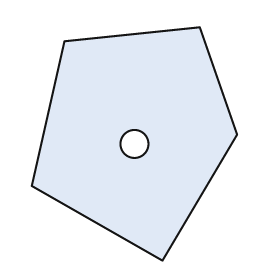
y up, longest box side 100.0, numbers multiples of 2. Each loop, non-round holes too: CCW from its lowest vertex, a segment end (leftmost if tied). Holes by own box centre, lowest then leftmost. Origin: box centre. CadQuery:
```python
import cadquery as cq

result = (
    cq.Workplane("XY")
    .moveTo(12.0, -50.0)
    .lineTo(44.0, 4.0)
    .lineTo(28.0, 50.0)
    .lineTo(-30.0, 44.0)
    .lineTo(-44.0, -18.0)
    .close()
    .moveTo(0.0, 0.0)
    .circle(6.0)
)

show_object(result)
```